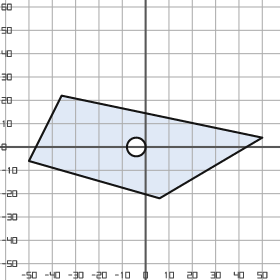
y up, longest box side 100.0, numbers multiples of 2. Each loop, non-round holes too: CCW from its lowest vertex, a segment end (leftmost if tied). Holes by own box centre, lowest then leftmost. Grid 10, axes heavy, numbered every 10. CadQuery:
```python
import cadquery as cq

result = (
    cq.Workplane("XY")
    .moveTo(6.0, -22.0)
    .lineTo(50.0, 4.0)
    .lineTo(-36.0, 22.0)
    .lineTo(-50.0, -6.0)
    .close()
    .moveTo(-4.0, 0.0)
    .circle(4.0)
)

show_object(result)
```